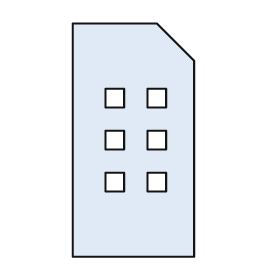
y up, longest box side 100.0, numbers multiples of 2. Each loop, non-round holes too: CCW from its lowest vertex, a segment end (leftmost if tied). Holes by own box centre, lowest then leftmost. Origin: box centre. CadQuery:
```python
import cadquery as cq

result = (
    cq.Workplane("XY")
    .moveTo(-26.0, -50.0)
    .lineTo(26.0, -50.0)
    .lineTo(26.0, 34.0)
    .lineTo(10.0, 50.0)
    .lineTo(-26.0, 50.0)
    .close()
    .moveTo(-12.0, -22.0)
    .lineTo(-4.0, -22.0)
    .lineTo(-4.0, -14.0)
    .lineTo(-12.0, -14.0)
    .close()
    .moveTo(6.0, -22.0)
    .lineTo(14.0, -22.0)
    .lineTo(14.0, -14.0)
    .lineTo(6.0, -14.0)
    .close()
    .moveTo(-12.0, -4.0)
    .lineTo(-4.0, -4.0)
    .lineTo(-4.0, 4.0)
    .lineTo(-12.0, 4.0)
    .close()
    .moveTo(6.0, -4.0)
    .lineTo(14.0, -4.0)
    .lineTo(14.0, 4.0)
    .lineTo(6.0, 4.0)
    .close()
    .moveTo(-12.0, 14.0)
    .lineTo(-4.0, 14.0)
    .lineTo(-4.0, 22.0)
    .lineTo(-12.0, 22.0)
    .close()
    .moveTo(6.0, 14.0)
    .lineTo(14.0, 14.0)
    .lineTo(14.0, 22.0)
    .lineTo(6.0, 22.0)
    .close()
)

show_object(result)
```